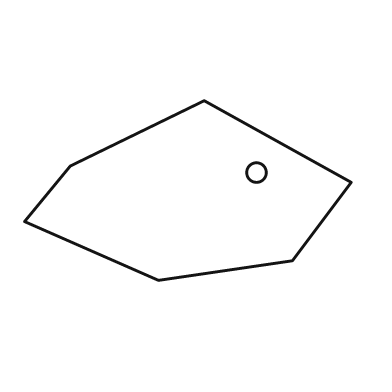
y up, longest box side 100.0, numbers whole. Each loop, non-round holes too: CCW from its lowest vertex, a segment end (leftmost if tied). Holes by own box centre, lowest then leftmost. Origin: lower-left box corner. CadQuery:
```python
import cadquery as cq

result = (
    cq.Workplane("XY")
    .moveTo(41.0, 0.0)
    .lineTo(82.0, 6.0)
    .lineTo(100.0, 30.0)
    .lineTo(55.0, 55.0)
    .lineTo(14.0, 35.0)
    .lineTo(0.0, 18.0)
    .close()
    .moveTo(71.0, 33.0)
    .circle(3.0)
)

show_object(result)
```